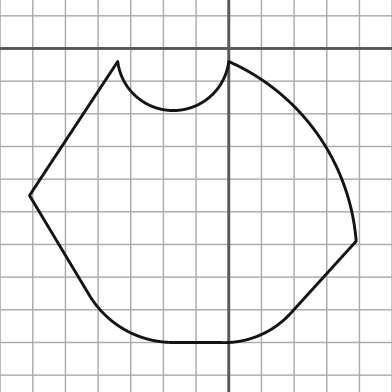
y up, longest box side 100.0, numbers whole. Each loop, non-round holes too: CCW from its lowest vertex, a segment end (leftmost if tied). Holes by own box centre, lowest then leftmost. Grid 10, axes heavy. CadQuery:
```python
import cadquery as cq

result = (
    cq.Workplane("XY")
    .moveTo(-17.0, -90.0)
    .lineTo(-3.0, -90.0)
    .threePointArc((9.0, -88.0), (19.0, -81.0))
    .lineTo(39.0, -59.0)
    .threePointArc((27.0, -26.0), (0.0, -4.0))
    .threePointArc((-17.0, -19.0), (-34.0, -4.0))
    .lineTo(-61.0, -45.0)
    .lineTo(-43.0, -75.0)
    .threePointArc((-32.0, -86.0), (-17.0, -90.0))
    .close()
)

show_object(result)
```